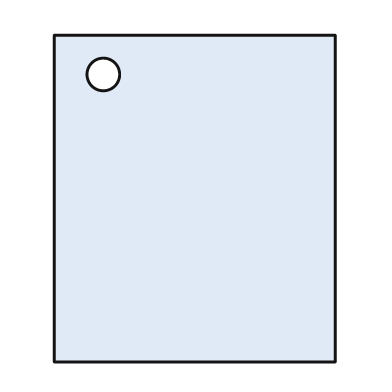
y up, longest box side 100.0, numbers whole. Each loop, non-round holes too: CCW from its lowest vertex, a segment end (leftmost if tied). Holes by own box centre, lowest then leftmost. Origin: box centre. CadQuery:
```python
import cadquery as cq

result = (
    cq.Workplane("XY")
    .moveTo(-43.0, -50.0)
    .lineTo(43.0, -50.0)
    .lineTo(43.0, 50.0)
    .lineTo(-43.0, 50.0)
    .close()
    .moveTo(-28.0, 38.0)
    .circle(5.0)
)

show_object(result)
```